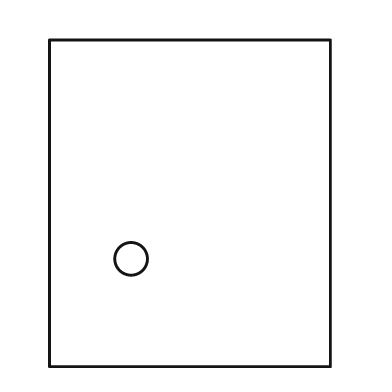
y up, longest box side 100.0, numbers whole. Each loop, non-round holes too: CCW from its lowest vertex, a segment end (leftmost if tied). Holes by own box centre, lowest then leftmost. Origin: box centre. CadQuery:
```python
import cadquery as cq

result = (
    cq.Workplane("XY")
    .moveTo(-43.0, -50.0)
    .lineTo(43.0, -50.0)
    .lineTo(43.0, 50.0)
    .lineTo(-43.0, 50.0)
    .close()
    .moveTo(-18.0, -17.0)
    .circle(5.0)
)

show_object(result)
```